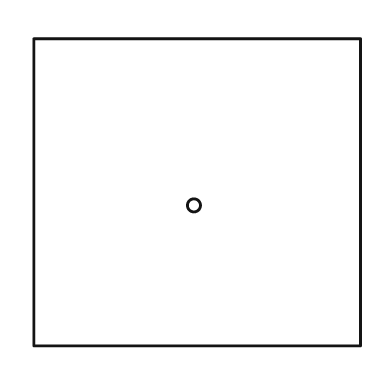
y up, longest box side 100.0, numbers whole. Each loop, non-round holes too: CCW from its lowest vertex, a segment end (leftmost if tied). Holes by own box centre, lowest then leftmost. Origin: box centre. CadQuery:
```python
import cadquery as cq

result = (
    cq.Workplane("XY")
    .moveTo(-50.0, -47.0)
    .lineTo(50.0, -47.0)
    .lineTo(50.0, 47.0)
    .lineTo(-50.0, 47.0)
    .close()
    .moveTo(-1.0, -4.0)
    .circle(2.0)
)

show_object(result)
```